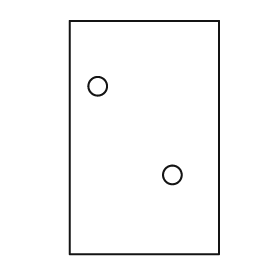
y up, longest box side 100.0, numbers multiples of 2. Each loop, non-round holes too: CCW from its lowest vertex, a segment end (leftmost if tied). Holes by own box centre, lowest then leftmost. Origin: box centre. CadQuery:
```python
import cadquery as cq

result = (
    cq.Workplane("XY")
    .moveTo(-32.0, -50.0)
    .lineTo(32.0, -50.0)
    .lineTo(32.0, 50.0)
    .lineTo(-32.0, 50.0)
    .close()
    .moveTo(12.0, -16.0)
    .circle(4.0)
    .moveTo(-20.0, 22.0)
    .circle(4.0)
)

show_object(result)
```